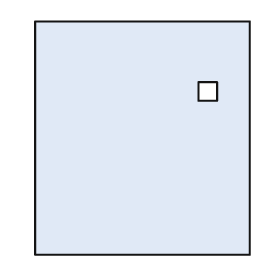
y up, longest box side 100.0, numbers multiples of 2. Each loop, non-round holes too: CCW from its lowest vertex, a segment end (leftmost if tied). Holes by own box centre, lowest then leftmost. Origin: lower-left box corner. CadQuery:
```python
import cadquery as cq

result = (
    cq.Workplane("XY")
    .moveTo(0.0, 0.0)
    .lineTo(92.0, 0.0)
    .lineTo(92.0, 100.0)
    .lineTo(0.0, 100.0)
    .close()
    .moveTo(70.0, 66.0)
    .lineTo(78.0, 66.0)
    .lineTo(78.0, 74.0)
    .lineTo(70.0, 74.0)
    .close()
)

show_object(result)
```